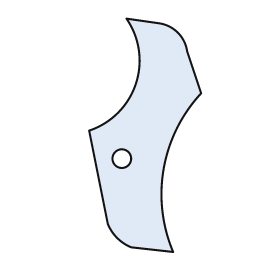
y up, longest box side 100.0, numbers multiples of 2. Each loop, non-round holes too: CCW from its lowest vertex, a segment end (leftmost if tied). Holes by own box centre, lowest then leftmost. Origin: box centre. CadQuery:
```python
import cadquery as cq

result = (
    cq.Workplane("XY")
    .moveTo(12.0, -50.0)
    .threePointArc((8.0, -14.0), (24.0, 18.0))
    .lineTo(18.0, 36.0)
    .threePointArc((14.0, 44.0), (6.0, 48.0))
    .lineTo(-8.0, 50.0)
    .threePointArc((-4.0, 22.0), (-24.0, 2.0))
    .lineTo(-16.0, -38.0)
    .threePointArc((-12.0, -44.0), (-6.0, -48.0))
    .close()
    .moveTo(-10.0, -10.0)
    .circle(4.0)
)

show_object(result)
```